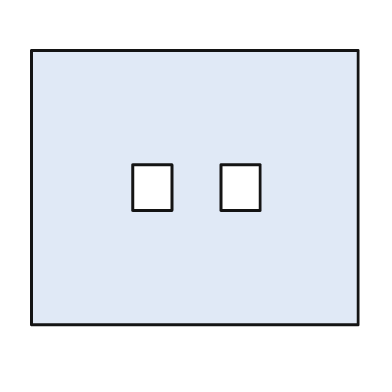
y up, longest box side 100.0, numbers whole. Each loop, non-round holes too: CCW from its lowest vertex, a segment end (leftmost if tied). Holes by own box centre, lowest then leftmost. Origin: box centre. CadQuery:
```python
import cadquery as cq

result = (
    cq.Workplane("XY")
    .moveTo(-50.0, -42.0)
    .lineTo(50.0, -42.0)
    .lineTo(50.0, 42.0)
    .lineTo(-50.0, 42.0)
    .close()
    .moveTo(-19.0, -7.0)
    .lineTo(-7.0, -7.0)
    .lineTo(-7.0, 7.0)
    .lineTo(-19.0, 7.0)
    .close()
    .moveTo(8.0, -7.0)
    .lineTo(20.0, -7.0)
    .lineTo(20.0, 7.0)
    .lineTo(8.0, 7.0)
    .close()
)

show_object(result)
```